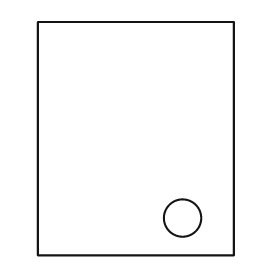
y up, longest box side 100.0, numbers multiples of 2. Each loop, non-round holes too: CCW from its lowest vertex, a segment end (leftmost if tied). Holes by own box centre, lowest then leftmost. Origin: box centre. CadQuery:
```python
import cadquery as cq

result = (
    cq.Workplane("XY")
    .moveTo(-42.0, -50.0)
    .lineTo(42.0, -50.0)
    .lineTo(42.0, 50.0)
    .lineTo(-42.0, 50.0)
    .close()
    .moveTo(20.0, -34.0)
    .circle(8.0)
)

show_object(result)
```